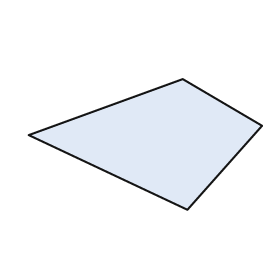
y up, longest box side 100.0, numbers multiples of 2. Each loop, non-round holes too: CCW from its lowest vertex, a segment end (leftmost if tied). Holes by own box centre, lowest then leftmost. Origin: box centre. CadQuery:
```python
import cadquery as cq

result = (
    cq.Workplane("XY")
    .moveTo(18.0, -28.0)
    .lineTo(50.0, 8.0)
    .lineTo(16.0, 28.0)
    .lineTo(-50.0, 4.0)
    .close()
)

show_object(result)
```